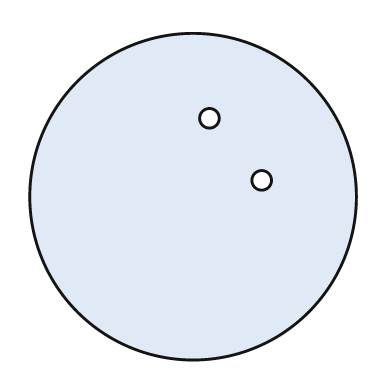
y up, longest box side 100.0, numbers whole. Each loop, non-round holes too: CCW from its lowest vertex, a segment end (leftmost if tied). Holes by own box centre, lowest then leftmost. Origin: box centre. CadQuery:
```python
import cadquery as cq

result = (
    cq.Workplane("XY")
    .moveTo(0.0, 0.0)
    .circle(50.0)
    .moveTo(21.0, 5.0)
    .circle(3.0)
    .moveTo(5.0, 24.0)
    .circle(3.0)
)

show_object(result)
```